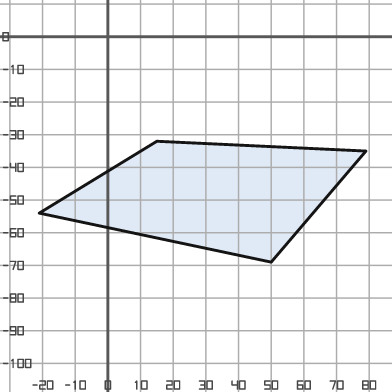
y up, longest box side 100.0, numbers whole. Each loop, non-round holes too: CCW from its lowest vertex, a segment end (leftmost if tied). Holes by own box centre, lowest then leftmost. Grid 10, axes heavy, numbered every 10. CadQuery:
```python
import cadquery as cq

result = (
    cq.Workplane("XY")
    .moveTo(50.0, -69.0)
    .lineTo(79.0, -35.0)
    .lineTo(15.0, -32.0)
    .lineTo(-21.0, -54.0)
    .close()
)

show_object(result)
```